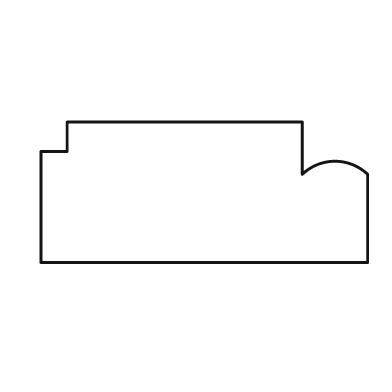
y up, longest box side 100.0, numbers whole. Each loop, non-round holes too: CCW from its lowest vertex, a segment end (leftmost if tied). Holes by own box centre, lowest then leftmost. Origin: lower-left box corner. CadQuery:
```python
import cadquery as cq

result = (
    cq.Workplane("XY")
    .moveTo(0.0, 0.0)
    .lineTo(100.0, 0.0)
    .lineTo(100.0, 27.0)
    .threePointArc((90.0, 31.0), (80.0, 27.0))
    .lineTo(80.0, 43.0)
    .lineTo(8.0, 43.0)
    .lineTo(8.0, 34.0)
    .lineTo(0.0, 34.0)
    .close()
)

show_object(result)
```